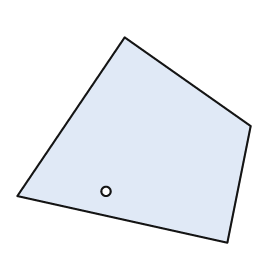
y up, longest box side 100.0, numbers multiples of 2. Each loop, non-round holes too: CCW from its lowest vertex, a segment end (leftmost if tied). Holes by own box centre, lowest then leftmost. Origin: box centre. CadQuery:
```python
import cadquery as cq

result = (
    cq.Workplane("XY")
    .moveTo(40.0, -44.0)
    .lineTo(50.0, 6.0)
    .lineTo(-4.0, 44.0)
    .lineTo(-50.0, -24.0)
    .close()
    .moveTo(-12.0, -22.0)
    .circle(2.0)
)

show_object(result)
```